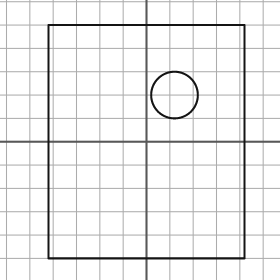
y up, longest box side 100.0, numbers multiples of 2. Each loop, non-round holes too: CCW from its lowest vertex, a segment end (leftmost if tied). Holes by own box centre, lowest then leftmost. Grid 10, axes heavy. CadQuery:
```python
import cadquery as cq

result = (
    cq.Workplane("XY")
    .moveTo(-42.0, -50.0)
    .lineTo(42.0, -50.0)
    .lineTo(42.0, 50.0)
    .lineTo(-42.0, 50.0)
    .close()
    .moveTo(12.0, 20.0)
    .circle(10.0)
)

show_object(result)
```